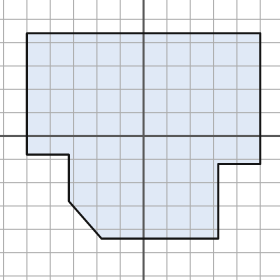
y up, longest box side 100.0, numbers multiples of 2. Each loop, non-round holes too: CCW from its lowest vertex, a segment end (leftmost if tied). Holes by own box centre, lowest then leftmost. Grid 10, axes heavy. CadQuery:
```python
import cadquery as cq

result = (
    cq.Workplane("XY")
    .moveTo(-18.0, -44.0)
    .lineTo(32.0, -44.0)
    .lineTo(32.0, -12.0)
    .lineTo(50.0, -12.0)
    .lineTo(50.0, 44.0)
    .lineTo(-50.0, 44.0)
    .lineTo(-50.0, -8.0)
    .lineTo(-32.0, -8.0)
    .lineTo(-32.0, -28.0)
    .close()
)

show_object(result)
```